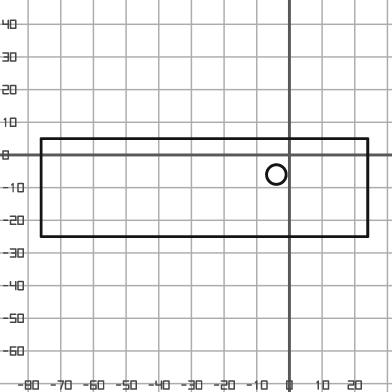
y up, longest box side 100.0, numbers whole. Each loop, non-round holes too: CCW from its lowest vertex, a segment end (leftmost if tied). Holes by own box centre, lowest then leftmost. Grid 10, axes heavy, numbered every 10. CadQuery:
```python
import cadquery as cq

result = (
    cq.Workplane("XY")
    .moveTo(-76.0, -25.0)
    .lineTo(24.0, -25.0)
    .lineTo(24.0, 5.0)
    .lineTo(-76.0, 5.0)
    .close()
    .moveTo(-4.0, -6.0)
    .circle(3.0)
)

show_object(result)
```